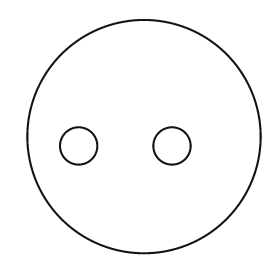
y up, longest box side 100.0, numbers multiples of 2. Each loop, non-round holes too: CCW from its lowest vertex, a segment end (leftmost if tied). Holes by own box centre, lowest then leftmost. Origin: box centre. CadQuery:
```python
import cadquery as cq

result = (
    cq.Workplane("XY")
    .moveTo(0.0, 0.0)
    .circle(50.0)
    .moveTo(-28.0, -4.0)
    .circle(8.0)
    .moveTo(12.0, -4.0)
    .circle(8.0)
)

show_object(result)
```